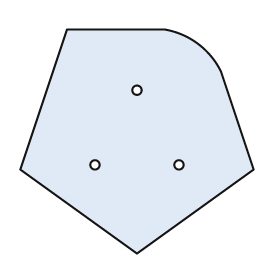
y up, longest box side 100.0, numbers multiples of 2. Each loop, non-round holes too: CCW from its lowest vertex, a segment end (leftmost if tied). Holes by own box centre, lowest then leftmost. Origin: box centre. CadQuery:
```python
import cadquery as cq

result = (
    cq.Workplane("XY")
    .moveTo(0.0, -48.0)
    .lineTo(50.0, -12.0)
    .lineTo(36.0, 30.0)
    .threePointArc((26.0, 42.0), (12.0, 48.0))
    .lineTo(-30.0, 48.0)
    .lineTo(-50.0, -12.0)
    .close()
    .moveTo(-18.0, -10.0)
    .circle(2.0)
    .moveTo(18.0, -10.0)
    .circle(2.0)
    .moveTo(0.0, 22.0)
    .circle(2.0)
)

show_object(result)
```